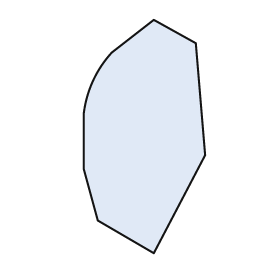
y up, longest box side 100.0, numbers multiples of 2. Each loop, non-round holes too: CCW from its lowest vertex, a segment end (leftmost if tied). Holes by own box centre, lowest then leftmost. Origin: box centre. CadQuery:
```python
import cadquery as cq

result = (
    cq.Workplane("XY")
    .moveTo(4.0, -50.0)
    .lineTo(26.0, -8.0)
    .lineTo(22.0, 40.0)
    .lineTo(4.0, 50.0)
    .lineTo(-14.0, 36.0)
    .threePointArc((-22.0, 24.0), (-26.0, 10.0))
    .lineTo(-26.0, -14.0)
    .lineTo(-20.0, -36.0)
    .close()
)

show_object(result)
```